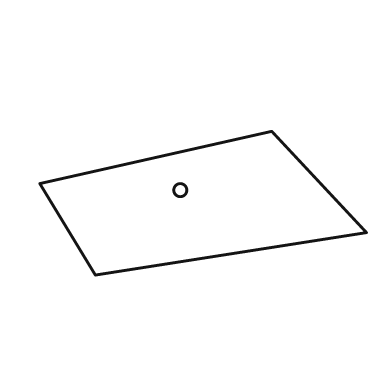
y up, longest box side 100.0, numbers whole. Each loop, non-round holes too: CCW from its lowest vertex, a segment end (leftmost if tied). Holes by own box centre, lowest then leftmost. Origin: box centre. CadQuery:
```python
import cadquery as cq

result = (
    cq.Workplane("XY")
    .moveTo(-33.0, -22.0)
    .lineTo(50.0, -9.0)
    .lineTo(21.0, 22.0)
    .lineTo(-50.0, 6.0)
    .close()
    .moveTo(-7.0, 4.0)
    .circle(2.0)
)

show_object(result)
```